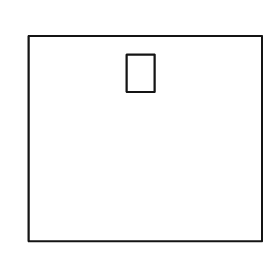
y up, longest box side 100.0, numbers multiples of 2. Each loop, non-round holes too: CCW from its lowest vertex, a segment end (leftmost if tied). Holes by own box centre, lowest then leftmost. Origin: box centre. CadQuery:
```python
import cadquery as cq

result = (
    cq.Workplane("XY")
    .moveTo(-50.0, -44.0)
    .lineTo(50.0, -44.0)
    .lineTo(50.0, 44.0)
    .lineTo(-50.0, 44.0)
    .close()
    .moveTo(-8.0, 20.0)
    .lineTo(4.0, 20.0)
    .lineTo(4.0, 36.0)
    .lineTo(-8.0, 36.0)
    .close()
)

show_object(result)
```